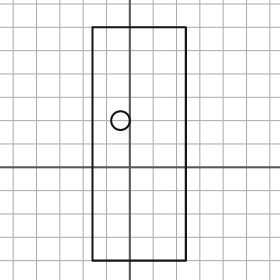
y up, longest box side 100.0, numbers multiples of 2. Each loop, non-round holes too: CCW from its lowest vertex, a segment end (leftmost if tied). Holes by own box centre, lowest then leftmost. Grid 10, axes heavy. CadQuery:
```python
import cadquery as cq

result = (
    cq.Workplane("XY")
    .moveTo(-16.0, -40.0)
    .lineTo(24.0, -40.0)
    .lineTo(24.0, 60.0)
    .lineTo(-16.0, 60.0)
    .close()
    .moveTo(-4.0, 20.0)
    .circle(4.0)
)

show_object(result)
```